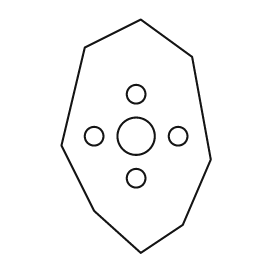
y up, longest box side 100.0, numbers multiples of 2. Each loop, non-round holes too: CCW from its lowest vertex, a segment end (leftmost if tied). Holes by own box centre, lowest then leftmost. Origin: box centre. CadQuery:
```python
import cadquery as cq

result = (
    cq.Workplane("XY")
    .moveTo(2.0, -50.0)
    .lineTo(20.0, -38.0)
    .lineTo(32.0, -10.0)
    .lineTo(24.0, 34.0)
    .lineTo(2.0, 50.0)
    .lineTo(-22.0, 38.0)
    .lineTo(-32.0, -4.0)
    .lineTo(-18.0, -32.0)
    .close()
    .moveTo(0.0, -18.0)
    .circle(4.0)
    .moveTo(-18.0, 0.0)
    .circle(4.0)
    .moveTo(0.0, 0.0)
    .circle(8.0)
    .moveTo(18.0, 0.0)
    .circle(4.0)
    .moveTo(0.0, 18.0)
    .circle(4.0)
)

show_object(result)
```